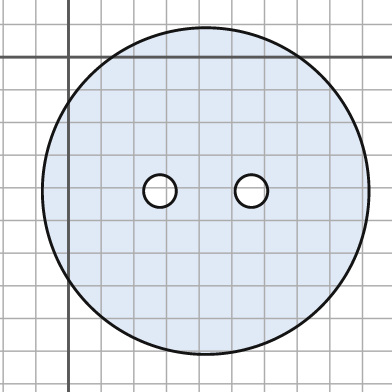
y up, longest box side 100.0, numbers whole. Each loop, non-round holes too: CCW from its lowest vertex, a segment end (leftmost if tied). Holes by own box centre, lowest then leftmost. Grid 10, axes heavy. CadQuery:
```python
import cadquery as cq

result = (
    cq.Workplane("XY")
    .moveTo(42.0, -41.0)
    .circle(50.0)
    .moveTo(28.0, -41.0)
    .circle(5.0)
    .moveTo(56.0, -41.0)
    .circle(5.0)
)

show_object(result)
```